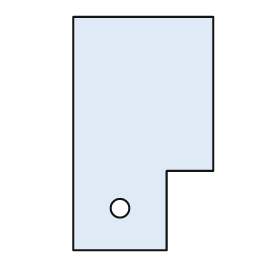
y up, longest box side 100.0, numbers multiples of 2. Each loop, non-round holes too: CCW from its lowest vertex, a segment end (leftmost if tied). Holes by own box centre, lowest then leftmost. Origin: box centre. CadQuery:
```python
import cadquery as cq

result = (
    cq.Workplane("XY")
    .moveTo(-30.0, -50.0)
    .lineTo(10.0, -50.0)
    .lineTo(10.0, -16.0)
    .lineTo(30.0, -16.0)
    .lineTo(30.0, 50.0)
    .lineTo(-30.0, 50.0)
    .close()
    .moveTo(-10.0, -32.0)
    .circle(4.0)
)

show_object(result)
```